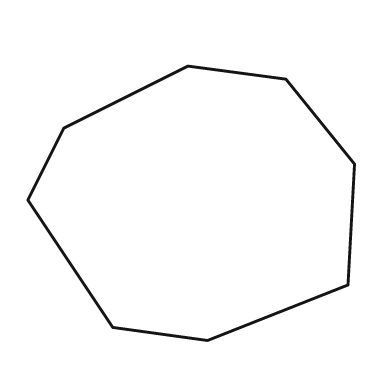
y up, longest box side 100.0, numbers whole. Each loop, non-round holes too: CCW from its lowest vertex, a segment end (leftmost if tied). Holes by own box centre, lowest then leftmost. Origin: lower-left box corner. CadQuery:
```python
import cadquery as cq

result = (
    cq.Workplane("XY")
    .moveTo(55.0, 0.0)
    .lineTo(98.0, 17.0)
    .lineTo(100.0, 54.0)
    .lineTo(79.0, 80.0)
    .lineTo(49.0, 84.0)
    .lineTo(11.0, 65.0)
    .lineTo(0.0, 43.0)
    .lineTo(26.0, 4.0)
    .close()
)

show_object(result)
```